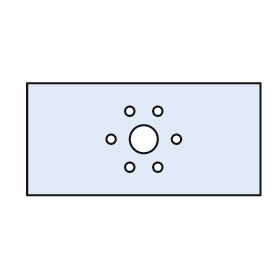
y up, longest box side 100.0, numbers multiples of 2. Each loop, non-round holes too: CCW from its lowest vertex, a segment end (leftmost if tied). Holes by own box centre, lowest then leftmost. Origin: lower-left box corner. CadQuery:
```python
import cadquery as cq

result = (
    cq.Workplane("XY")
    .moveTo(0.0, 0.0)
    .lineTo(100.0, 0.0)
    .lineTo(100.0, 48.0)
    .lineTo(0.0, 48.0)
    .close()
    .moveTo(44.0, 12.0)
    .circle(2.0)
    .moveTo(56.0, 12.0)
    .circle(2.0)
    .moveTo(36.0, 24.0)
    .circle(2.0)
    .moveTo(50.0, 24.0)
    .circle(6.0)
    .moveTo(64.0, 24.0)
    .circle(2.0)
    .moveTo(44.0, 36.0)
    .circle(2.0)
    .moveTo(56.0, 36.0)
    .circle(2.0)
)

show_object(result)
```